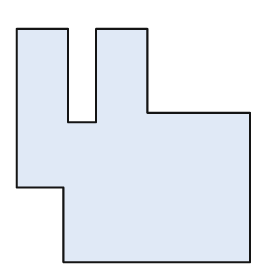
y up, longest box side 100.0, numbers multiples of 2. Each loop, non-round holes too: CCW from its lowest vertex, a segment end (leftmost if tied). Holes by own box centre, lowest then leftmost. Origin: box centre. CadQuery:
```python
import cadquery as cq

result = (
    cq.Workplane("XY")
    .moveTo(-30.0, -50.0)
    .lineTo(50.0, -50.0)
    .lineTo(50.0, 14.0)
    .lineTo(6.0, 14.0)
    .lineTo(6.0, 50.0)
    .lineTo(-16.0, 50.0)
    .lineTo(-16.0, 10.0)
    .lineTo(-28.0, 10.0)
    .lineTo(-28.0, 50.0)
    .lineTo(-50.0, 50.0)
    .lineTo(-50.0, -18.0)
    .lineTo(-30.0, -18.0)
    .close()
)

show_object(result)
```